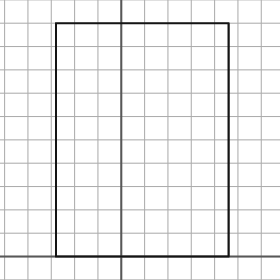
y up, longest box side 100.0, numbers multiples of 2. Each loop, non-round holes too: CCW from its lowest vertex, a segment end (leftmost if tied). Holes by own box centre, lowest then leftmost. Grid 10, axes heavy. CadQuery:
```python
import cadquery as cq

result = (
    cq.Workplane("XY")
    .moveTo(-28.0, 0.0)
    .lineTo(46.0, 0.0)
    .lineTo(46.0, 100.0)
    .lineTo(-28.0, 100.0)
    .close()
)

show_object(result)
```